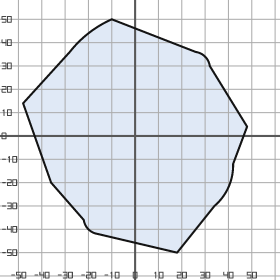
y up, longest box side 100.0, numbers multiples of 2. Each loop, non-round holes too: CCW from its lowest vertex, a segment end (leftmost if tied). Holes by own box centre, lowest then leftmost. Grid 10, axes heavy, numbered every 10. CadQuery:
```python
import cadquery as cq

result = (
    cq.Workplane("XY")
    .moveTo(18.0, -50.0)
    .lineTo(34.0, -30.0)
    .threePointArc((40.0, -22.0), (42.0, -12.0))
    .lineTo(48.0, 4.0)
    .lineTo(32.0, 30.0)
    .threePointArc((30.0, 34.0), (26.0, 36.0))
    .lineTo(-10.0, 50.0)
    .threePointArc((-20.0, 44.0), (-28.0, 36.0))
    .lineTo(-48.0, 14.0)
    .lineTo(-36.0, -20.0)
    .lineTo(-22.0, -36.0)
    .threePointArc((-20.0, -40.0), (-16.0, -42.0))
    .close()
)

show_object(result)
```